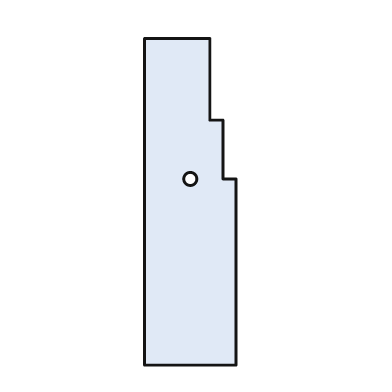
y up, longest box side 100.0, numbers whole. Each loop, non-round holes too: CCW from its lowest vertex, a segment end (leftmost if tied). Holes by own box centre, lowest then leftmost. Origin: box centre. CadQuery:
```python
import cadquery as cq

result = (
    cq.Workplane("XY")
    .moveTo(-14.0, -50.0)
    .lineTo(14.0, -50.0)
    .lineTo(14.0, 7.0)
    .lineTo(10.0, 7.0)
    .lineTo(10.0, 25.0)
    .lineTo(6.0, 25.0)
    .lineTo(6.0, 50.0)
    .lineTo(-14.0, 50.0)
    .close()
    .moveTo(0.0, 7.0)
    .circle(2.0)
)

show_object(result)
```